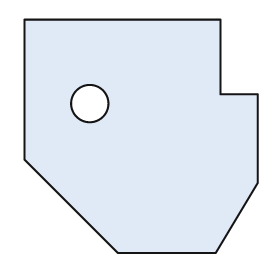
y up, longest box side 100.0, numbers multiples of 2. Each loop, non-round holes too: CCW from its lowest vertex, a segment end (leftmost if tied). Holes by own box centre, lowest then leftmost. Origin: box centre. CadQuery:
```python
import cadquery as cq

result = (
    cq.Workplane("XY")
    .moveTo(-10.0, -50.0)
    .lineTo(32.0, -50.0)
    .lineTo(50.0, -20.0)
    .lineTo(50.0, 18.0)
    .lineTo(34.0, 18.0)
    .lineTo(34.0, 50.0)
    .lineTo(-50.0, 50.0)
    .lineTo(-50.0, -10.0)
    .close()
    .moveTo(-22.0, 14.0)
    .circle(8.0)
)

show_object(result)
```